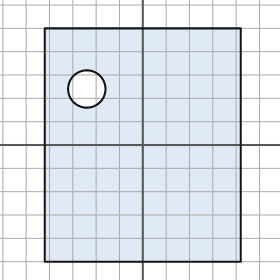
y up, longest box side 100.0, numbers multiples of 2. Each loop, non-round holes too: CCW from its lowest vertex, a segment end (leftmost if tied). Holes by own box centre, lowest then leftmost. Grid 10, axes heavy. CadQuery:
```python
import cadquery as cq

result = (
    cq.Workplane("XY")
    .moveTo(-42.0, -50.0)
    .lineTo(42.0, -50.0)
    .lineTo(42.0, 50.0)
    .lineTo(-42.0, 50.0)
    .close()
    .moveTo(-24.0, 24.0)
    .circle(8.0)
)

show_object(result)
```